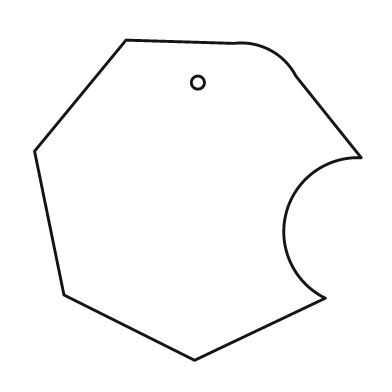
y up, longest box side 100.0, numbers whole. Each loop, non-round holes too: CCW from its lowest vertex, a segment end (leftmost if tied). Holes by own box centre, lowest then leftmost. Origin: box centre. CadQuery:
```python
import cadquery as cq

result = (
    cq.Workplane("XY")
    .moveTo(-1.0, -49.0)
    .lineTo(39.0, -30.0)
    .threePointArc((27.0, -4.0), (50.0, 13.0))
    .lineTo(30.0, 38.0)
    .threePointArc((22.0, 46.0), (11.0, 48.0))
    .lineTo(-22.0, 49.0)
    .lineTo(-50.0, 15.0)
    .lineTo(-41.0, -29.0)
    .close()
    .moveTo(0.0, 36.0)
    .circle(2.0)
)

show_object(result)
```